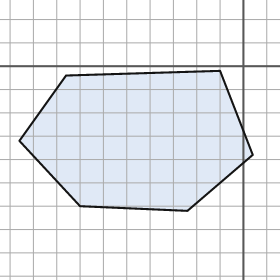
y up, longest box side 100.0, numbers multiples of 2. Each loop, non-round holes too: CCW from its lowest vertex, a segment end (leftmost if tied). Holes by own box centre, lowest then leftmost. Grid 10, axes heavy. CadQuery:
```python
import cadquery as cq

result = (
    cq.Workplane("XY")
    .moveTo(-24.0, -62.0)
    .lineTo(4.0, -38.0)
    .lineTo(-10.0, -2.0)
    .lineTo(-76.0, -4.0)
    .lineTo(-96.0, -32.0)
    .lineTo(-70.0, -60.0)
    .close()
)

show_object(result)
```